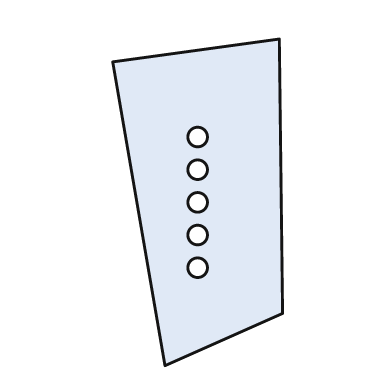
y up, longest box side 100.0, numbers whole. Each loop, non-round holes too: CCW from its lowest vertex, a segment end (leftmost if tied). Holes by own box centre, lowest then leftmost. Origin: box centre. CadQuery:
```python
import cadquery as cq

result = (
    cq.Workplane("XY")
    .moveTo(-10.0, -50.0)
    .lineTo(26.0, -34.0)
    .lineTo(25.0, 50.0)
    .lineTo(-26.0, 43.0)
    .close()
    .moveTo(0.0, -20.0)
    .circle(3.0)
    .moveTo(0.0, -10.0)
    .circle(3.0)
    .moveTo(0.0, 0.0)
    .circle(3.0)
    .moveTo(0.0, 10.0)
    .circle(3.0)
    .moveTo(0.0, 20.0)
    .circle(3.0)
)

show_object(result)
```